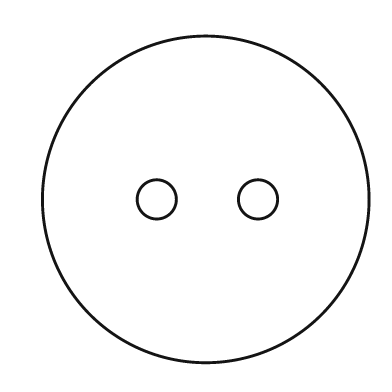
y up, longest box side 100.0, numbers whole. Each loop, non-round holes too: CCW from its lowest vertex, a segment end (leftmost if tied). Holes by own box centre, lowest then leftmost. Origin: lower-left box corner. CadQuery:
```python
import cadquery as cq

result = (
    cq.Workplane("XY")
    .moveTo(50.0, 50.0)
    .circle(50.0)
    .moveTo(35.0, 50.0)
    .circle(6.0)
    .moveTo(66.0, 50.0)
    .circle(6.0)
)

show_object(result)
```